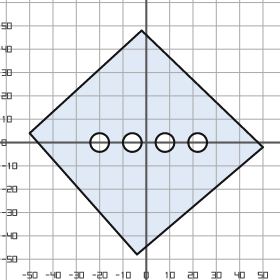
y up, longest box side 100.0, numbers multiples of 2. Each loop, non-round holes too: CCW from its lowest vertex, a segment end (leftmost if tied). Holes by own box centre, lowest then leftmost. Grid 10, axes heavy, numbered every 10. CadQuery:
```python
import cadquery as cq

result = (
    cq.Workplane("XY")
    .moveTo(-4.0, -48.0)
    .lineTo(50.0, -2.0)
    .lineTo(-2.0, 48.0)
    .lineTo(-50.0, 4.0)
    .close()
    .moveTo(-20.0, 0.0)
    .circle(4.0)
    .moveTo(-6.0, 0.0)
    .circle(4.0)
    .moveTo(8.0, 0.0)
    .circle(4.0)
    .moveTo(22.0, 0.0)
    .circle(4.0)
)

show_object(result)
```